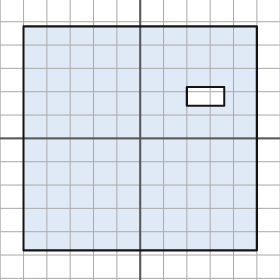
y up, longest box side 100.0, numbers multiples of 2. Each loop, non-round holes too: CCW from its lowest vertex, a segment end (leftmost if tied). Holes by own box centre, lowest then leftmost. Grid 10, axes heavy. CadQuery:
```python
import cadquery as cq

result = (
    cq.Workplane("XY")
    .moveTo(-50.0, -48.0)
    .lineTo(50.0, -48.0)
    .lineTo(50.0, 48.0)
    .lineTo(-50.0, 48.0)
    .close()
    .moveTo(20.0, 14.0)
    .lineTo(36.0, 14.0)
    .lineTo(36.0, 22.0)
    .lineTo(20.0, 22.0)
    .close()
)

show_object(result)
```